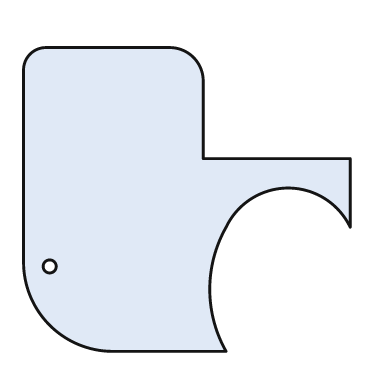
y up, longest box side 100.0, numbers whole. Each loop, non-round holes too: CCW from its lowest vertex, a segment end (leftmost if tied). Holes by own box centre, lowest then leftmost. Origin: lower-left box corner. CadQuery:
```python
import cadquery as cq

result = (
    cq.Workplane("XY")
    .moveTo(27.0, 0.0)
    .lineTo(62.0, 0.0)
    .threePointArc((57.0, 19.0), (62.0, 38.0))
    .threePointArc((81.0, 50.0), (100.0, 38.0))
    .lineTo(100.0, 59.0)
    .lineTo(55.0, 59.0)
    .lineTo(55.0, 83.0)
    .threePointArc((52.0, 90.0), (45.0, 93.0))
    .lineTo(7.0, 93.0)
    .threePointArc((2.0, 91.0), (0.0, 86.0))
    .lineTo(0.0, 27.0)
    .threePointArc((8.0, 8.0), (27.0, 0.0))
    .close()
    .moveTo(8.0, 26.0)
    .circle(2.0)
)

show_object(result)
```